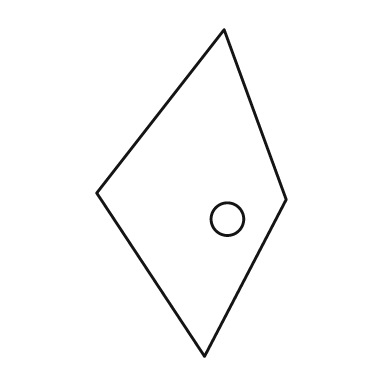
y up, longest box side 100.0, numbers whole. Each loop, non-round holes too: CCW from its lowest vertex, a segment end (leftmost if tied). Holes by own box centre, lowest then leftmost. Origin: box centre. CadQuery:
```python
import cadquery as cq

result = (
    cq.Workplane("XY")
    .moveTo(4.0, -50.0)
    .lineTo(29.0, -2.0)
    .lineTo(10.0, 50.0)
    .lineTo(-29.0, 0.0)
    .close()
    .moveTo(11.0, -8.0)
    .circle(5.0)
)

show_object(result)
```